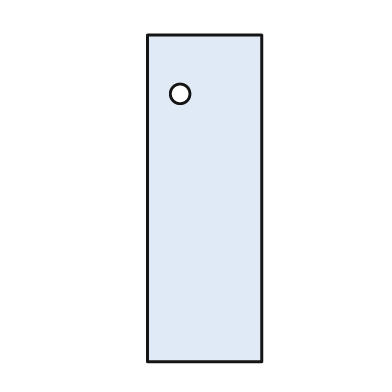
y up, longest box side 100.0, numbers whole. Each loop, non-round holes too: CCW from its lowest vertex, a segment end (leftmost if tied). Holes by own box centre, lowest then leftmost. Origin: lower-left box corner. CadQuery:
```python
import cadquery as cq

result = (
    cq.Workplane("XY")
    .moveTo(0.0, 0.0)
    .lineTo(35.0, 0.0)
    .lineTo(35.0, 100.0)
    .lineTo(0.0, 100.0)
    .close()
    .moveTo(10.0, 82.0)
    .circle(3.0)
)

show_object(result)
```